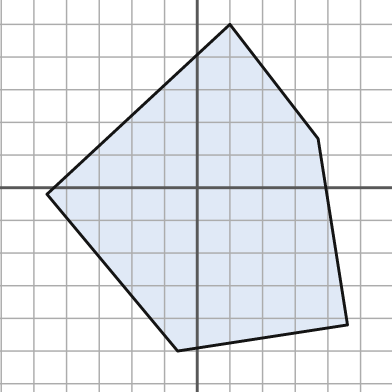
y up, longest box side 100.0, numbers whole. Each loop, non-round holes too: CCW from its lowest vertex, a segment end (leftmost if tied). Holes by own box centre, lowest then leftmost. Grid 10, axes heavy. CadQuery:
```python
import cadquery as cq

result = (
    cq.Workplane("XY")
    .moveTo(-6.0, -50.0)
    .lineTo(46.0, -42.0)
    .lineTo(37.0, 15.0)
    .lineTo(10.0, 50.0)
    .lineTo(-46.0, -2.0)
    .close()
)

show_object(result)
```